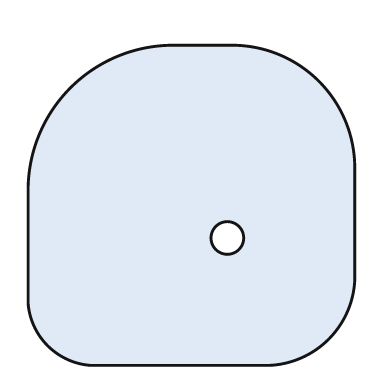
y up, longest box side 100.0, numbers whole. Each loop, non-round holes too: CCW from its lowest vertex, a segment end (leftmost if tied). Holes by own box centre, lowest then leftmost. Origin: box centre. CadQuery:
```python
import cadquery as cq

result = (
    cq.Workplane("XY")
    .moveTo(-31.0, -49.0)
    .lineTo(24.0, -49.0)
    .threePointArc((42.0, -41.0), (50.0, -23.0))
    .lineTo(50.0, 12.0)
    .threePointArc((39.0, 38.0), (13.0, 49.0))
    .lineTo(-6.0, 49.0)
    .threePointArc((-37.0, 36.0), (-50.0, 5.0))
    .lineTo(-50.0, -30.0)
    .threePointArc((-44.0, -43.0), (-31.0, -49.0))
    .close()
    .moveTo(11.0, -10.0)
    .circle(5.0)
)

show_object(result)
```